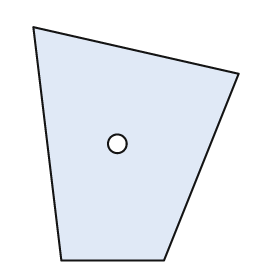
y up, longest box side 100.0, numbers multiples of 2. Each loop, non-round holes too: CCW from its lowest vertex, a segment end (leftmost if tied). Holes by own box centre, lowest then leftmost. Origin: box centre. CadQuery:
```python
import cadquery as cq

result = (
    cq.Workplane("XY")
    .moveTo(-32.0, -50.0)
    .lineTo(12.0, -50.0)
    .lineTo(44.0, 30.0)
    .lineTo(-44.0, 50.0)
    .close()
    .moveTo(-8.0, 0.0)
    .circle(4.0)
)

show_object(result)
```